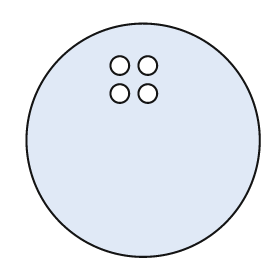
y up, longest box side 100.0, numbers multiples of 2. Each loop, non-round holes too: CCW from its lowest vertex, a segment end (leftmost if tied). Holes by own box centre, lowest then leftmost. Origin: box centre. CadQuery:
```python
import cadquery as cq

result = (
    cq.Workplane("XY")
    .moveTo(0.0, 0.0)
    .circle(50.0)
    .moveTo(-10.0, 20.0)
    .circle(4.0)
    .moveTo(2.0, 20.0)
    .circle(4.0)
    .moveTo(-10.0, 32.0)
    .circle(4.0)
    .moveTo(2.0, 32.0)
    .circle(4.0)
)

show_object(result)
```